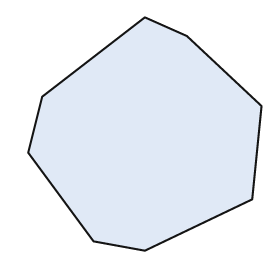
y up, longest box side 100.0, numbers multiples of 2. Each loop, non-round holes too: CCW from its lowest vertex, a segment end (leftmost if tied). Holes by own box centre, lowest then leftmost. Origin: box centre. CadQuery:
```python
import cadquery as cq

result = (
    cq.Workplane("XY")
    .moveTo(0.0, -50.0)
    .lineTo(46.0, -28.0)
    .lineTo(50.0, 12.0)
    .lineTo(18.0, 42.0)
    .lineTo(0.0, 50.0)
    .lineTo(-44.0, 16.0)
    .lineTo(-50.0, -8.0)
    .lineTo(-22.0, -46.0)
    .close()
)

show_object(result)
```